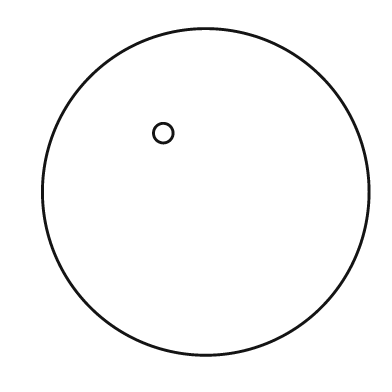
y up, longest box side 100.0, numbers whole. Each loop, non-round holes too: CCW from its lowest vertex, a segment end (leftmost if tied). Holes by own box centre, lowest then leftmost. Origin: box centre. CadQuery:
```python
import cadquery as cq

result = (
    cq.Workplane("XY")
    .moveTo(0.0, 0.0)
    .circle(50.0)
    .moveTo(-13.0, 18.0)
    .circle(3.0)
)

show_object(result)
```